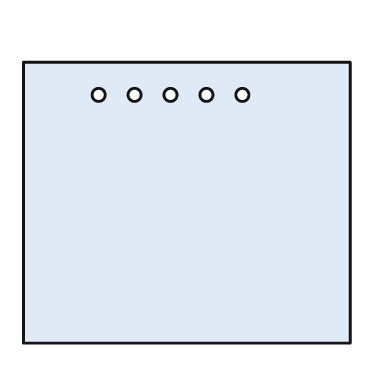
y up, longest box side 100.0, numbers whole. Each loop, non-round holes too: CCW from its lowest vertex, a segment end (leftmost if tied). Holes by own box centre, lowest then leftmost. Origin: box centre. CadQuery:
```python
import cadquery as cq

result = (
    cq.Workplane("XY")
    .moveTo(-50.0, -43.0)
    .lineTo(50.0, -43.0)
    .lineTo(50.0, 43.0)
    .lineTo(-50.0, 43.0)
    .close()
    .moveTo(-27.0, 33.0)
    .circle(2.0)
    .moveTo(-16.0, 33.0)
    .circle(2.0)
    .moveTo(-5.0, 33.0)
    .circle(2.0)
    .moveTo(6.0, 33.0)
    .circle(2.0)
    .moveTo(17.0, 33.0)
    .circle(2.0)
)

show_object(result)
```